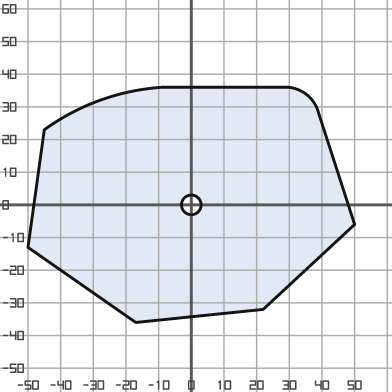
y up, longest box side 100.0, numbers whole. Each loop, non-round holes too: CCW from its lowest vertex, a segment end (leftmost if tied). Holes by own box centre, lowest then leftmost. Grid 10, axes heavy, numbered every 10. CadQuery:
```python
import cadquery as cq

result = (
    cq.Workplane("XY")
    .moveTo(-17.0, -36.0)
    .lineTo(22.0, -32.0)
    .lineTo(50.0, -6.0)
    .lineTo(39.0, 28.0)
    .threePointArc((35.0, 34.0), (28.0, 36.0))
    .lineTo(-9.0, 36.0)
    .threePointArc((-28.0, 32.0), (-45.0, 23.0))
    .lineTo(-50.0, -13.0)
    .close()
    .moveTo(0.0, 0.0)
    .circle(3.0)
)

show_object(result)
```